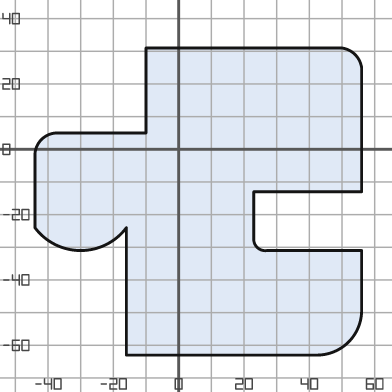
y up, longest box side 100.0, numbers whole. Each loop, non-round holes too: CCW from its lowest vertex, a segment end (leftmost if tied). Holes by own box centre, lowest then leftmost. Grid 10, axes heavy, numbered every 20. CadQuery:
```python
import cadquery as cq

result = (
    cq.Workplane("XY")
    .moveTo(-16.0, -63.0)
    .lineTo(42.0, -63.0)
    .threePointArc((52.0, -59.0), (56.0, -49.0))
    .lineTo(56.0, -31.0)
    .lineTo(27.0, -31.0)
    .threePointArc((24.0, -30.0), (23.0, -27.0))
    .lineTo(23.0, -13.0)
    .lineTo(56.0, -13.0)
    .lineTo(56.0, 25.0)
    .threePointArc((54.0, 29.0), (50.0, 31.0))
    .lineTo(-10.0, 31.0)
    .lineTo(-10.0, 5.0)
    .lineTo(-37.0, 5.0)
    .threePointArc((-42.0, 3.0), (-44.0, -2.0))
    .lineTo(-44.0, -24.0)
    .threePointArc((-30.0, -31.0), (-16.0, -24.0))
    .close()
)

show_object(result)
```